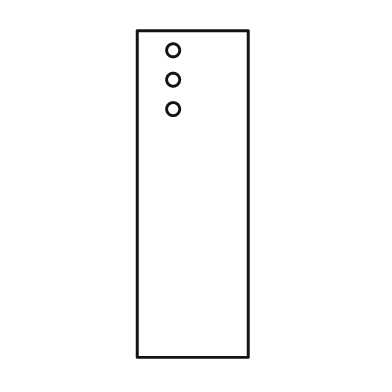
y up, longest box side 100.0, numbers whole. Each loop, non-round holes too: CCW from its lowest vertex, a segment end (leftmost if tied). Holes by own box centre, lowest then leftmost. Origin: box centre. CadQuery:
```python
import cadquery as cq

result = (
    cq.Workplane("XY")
    .moveTo(-17.0, -50.0)
    .lineTo(17.0, -50.0)
    .lineTo(17.0, 50.0)
    .lineTo(-17.0, 50.0)
    .close()
    .moveTo(-6.0, 26.0)
    .circle(2.0)
    .moveTo(-6.0, 35.0)
    .circle(2.0)
    .moveTo(-6.0, 44.0)
    .circle(2.0)
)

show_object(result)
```